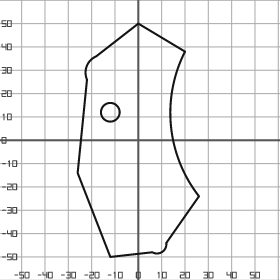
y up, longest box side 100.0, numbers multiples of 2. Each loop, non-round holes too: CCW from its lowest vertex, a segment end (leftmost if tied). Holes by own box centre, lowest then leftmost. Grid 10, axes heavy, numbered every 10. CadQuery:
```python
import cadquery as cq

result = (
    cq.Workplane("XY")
    .moveTo(-12.0, -50.0)
    .lineTo(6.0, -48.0)
    .threePointArc((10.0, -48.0), (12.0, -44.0))
    .lineTo(26.0, -24.0)
    .threePointArc((14.0, 6.0), (20.0, 38.0))
    .lineTo(0.0, 50.0)
    .lineTo(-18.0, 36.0)
    .threePointArc((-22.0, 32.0), (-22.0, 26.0))
    .lineTo(-26.0, -14.0)
    .close()
    .moveTo(-12.0, 12.0)
    .circle(4.0)
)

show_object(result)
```